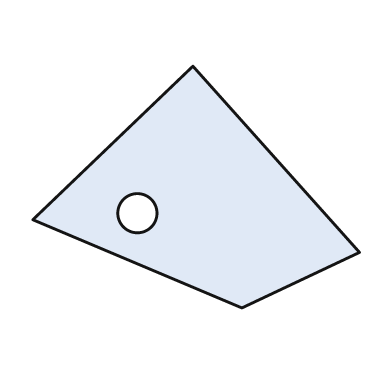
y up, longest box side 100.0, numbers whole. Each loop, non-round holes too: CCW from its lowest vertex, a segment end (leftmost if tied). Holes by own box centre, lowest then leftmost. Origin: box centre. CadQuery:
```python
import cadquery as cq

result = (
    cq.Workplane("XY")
    .moveTo(14.0, -37.0)
    .lineTo(50.0, -20.0)
    .lineTo(-1.0, 37.0)
    .lineTo(-50.0, -10.0)
    .close()
    .moveTo(-18.0, -8.0)
    .circle(6.0)
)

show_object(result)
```